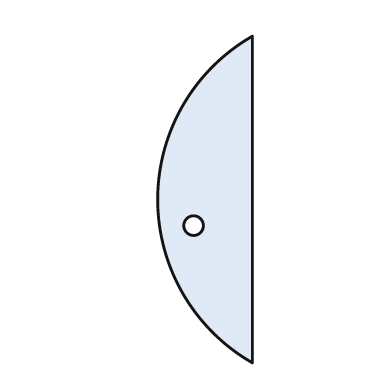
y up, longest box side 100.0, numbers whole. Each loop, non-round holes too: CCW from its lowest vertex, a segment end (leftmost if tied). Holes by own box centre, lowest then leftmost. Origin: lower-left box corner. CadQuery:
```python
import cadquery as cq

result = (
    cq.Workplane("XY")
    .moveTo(29.0, 0.0)
    .lineTo(29.0, 100.0)
    .threePointArc((0.0, 50.0), (29.0, 0.0))
    .close()
    .moveTo(11.0, 42.0)
    .circle(3.0)
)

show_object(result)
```